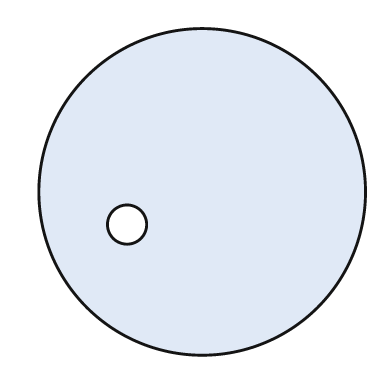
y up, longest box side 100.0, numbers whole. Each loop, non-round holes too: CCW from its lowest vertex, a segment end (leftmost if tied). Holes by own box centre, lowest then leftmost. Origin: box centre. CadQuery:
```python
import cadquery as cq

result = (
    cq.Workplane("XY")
    .moveTo(0.0, 0.0)
    .circle(50.0)
    .moveTo(-23.0, -10.0)
    .circle(6.0)
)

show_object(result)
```